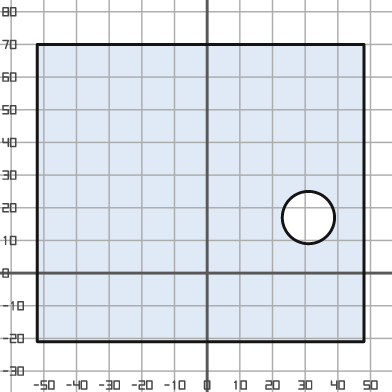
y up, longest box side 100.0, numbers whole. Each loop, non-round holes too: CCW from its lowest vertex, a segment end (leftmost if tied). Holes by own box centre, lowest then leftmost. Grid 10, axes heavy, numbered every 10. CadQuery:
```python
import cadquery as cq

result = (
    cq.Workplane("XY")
    .moveTo(-52.0, -21.0)
    .lineTo(48.0, -21.0)
    .lineTo(48.0, 70.0)
    .lineTo(-52.0, 70.0)
    .close()
    .moveTo(31.0, 17.0)
    .circle(8.0)
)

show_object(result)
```